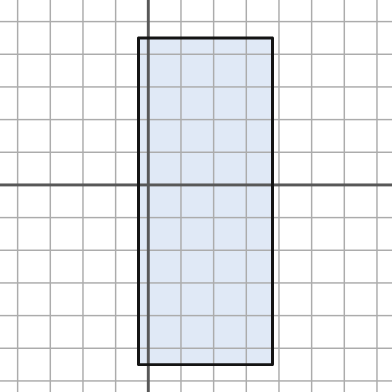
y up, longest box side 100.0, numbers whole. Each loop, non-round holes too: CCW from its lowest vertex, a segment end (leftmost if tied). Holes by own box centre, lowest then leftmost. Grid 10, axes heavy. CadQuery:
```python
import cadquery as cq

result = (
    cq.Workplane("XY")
    .moveTo(-3.0, -55.0)
    .lineTo(38.0, -55.0)
    .lineTo(38.0, 45.0)
    .lineTo(-3.0, 45.0)
    .close()
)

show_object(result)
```